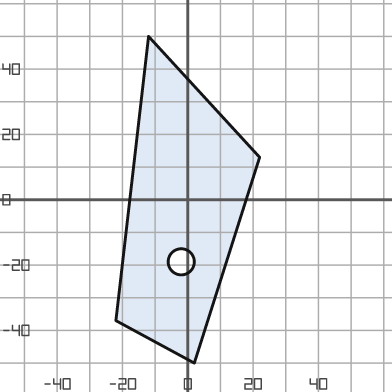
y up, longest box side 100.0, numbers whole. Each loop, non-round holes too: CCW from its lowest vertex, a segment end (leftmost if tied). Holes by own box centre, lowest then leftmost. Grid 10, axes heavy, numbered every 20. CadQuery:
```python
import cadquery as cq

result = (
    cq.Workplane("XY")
    .moveTo(2.0, -50.0)
    .lineTo(22.0, 13.0)
    .lineTo(-12.0, 50.0)
    .lineTo(-22.0, -37.0)
    .close()
    .moveTo(-2.0, -19.0)
    .circle(4.0)
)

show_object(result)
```